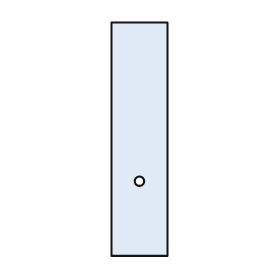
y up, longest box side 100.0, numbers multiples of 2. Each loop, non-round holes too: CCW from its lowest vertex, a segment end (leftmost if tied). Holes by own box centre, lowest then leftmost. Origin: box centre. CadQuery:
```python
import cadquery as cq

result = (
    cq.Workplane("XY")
    .moveTo(-12.0, -50.0)
    .lineTo(12.0, -50.0)
    .lineTo(12.0, 50.0)
    .lineTo(-12.0, 50.0)
    .close()
    .moveTo(0.0, -18.0)
    .circle(2.0)
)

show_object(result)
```